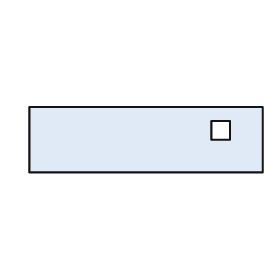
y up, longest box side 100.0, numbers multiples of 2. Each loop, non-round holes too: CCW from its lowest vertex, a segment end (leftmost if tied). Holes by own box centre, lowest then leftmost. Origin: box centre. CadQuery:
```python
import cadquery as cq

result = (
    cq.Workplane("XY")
    .moveTo(-50.0, -14.0)
    .lineTo(50.0, -14.0)
    .lineTo(50.0, 14.0)
    .lineTo(-50.0, 14.0)
    .close()
    .moveTo(28.0, 0.0)
    .lineTo(36.0, 0.0)
    .lineTo(36.0, 8.0)
    .lineTo(28.0, 8.0)
    .close()
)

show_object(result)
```